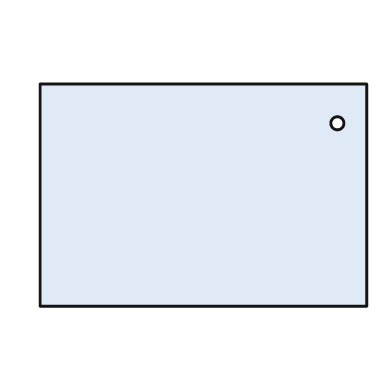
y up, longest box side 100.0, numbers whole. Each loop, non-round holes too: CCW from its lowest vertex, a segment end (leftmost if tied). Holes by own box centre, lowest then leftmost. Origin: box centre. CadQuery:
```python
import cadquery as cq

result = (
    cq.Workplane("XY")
    .moveTo(-50.0, -34.0)
    .lineTo(50.0, -34.0)
    .lineTo(50.0, 34.0)
    .lineTo(-50.0, 34.0)
    .close()
    .moveTo(41.0, 22.0)
    .circle(2.0)
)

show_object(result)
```